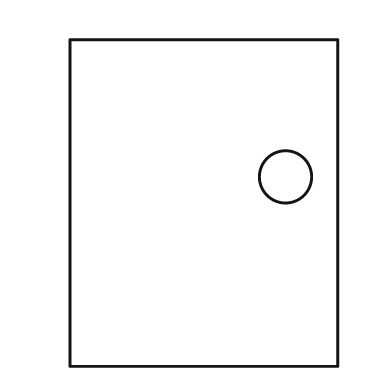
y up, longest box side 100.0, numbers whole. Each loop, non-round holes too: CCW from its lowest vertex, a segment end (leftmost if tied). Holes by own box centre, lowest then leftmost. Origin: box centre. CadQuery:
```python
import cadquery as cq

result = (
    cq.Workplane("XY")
    .moveTo(-41.0, -50.0)
    .lineTo(41.0, -50.0)
    .lineTo(41.0, 50.0)
    .lineTo(-41.0, 50.0)
    .close()
    .moveTo(25.0, 8.0)
    .circle(8.0)
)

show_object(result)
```